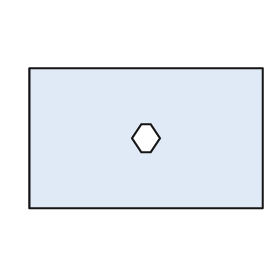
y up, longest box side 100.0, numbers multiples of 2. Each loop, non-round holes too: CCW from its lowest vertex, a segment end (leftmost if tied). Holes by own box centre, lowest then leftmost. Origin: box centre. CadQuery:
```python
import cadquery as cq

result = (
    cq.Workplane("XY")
    .moveTo(-50.0, -30.0)
    .lineTo(50.0, -30.0)
    .lineTo(50.0, 30.0)
    .lineTo(-50.0, 30.0)
    .close()
    .moveTo(-2.0, -6.0)
    .lineTo(2.0, -6.0)
    .lineTo(6.0, 0.0)
    .lineTo(2.0, 6.0)
    .lineTo(-2.0, 6.0)
    .lineTo(-6.0, 0.0)
    .close()
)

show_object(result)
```